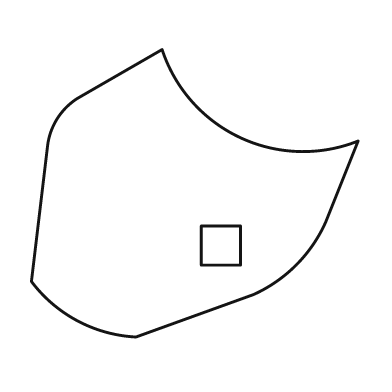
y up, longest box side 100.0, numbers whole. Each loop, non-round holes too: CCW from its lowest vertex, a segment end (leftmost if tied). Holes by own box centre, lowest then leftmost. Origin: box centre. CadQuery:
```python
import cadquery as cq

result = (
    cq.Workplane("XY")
    .moveTo(-18.0, -44.0)
    .lineTo(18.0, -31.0)
    .threePointArc((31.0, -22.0), (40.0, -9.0))
    .lineTo(50.0, 16.0)
    .threePointArc((14.0, 17.0), (-10.0, 44.0))
    .lineTo(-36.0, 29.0)
    .threePointArc((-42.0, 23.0), (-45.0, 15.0))
    .lineTo(-50.0, -27.0)
    .threePointArc((-36.0, -39.0), (-18.0, -44.0))
    .close()
    .moveTo(2.0, -22.0)
    .lineTo(14.0, -22.0)
    .lineTo(14.0, -10.0)
    .lineTo(2.0, -10.0)
    .close()
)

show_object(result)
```